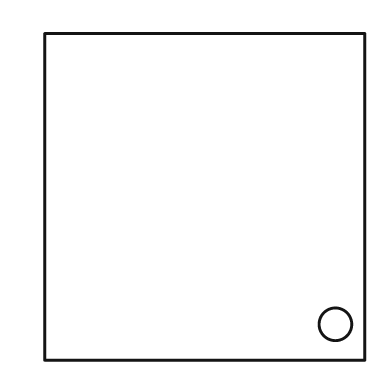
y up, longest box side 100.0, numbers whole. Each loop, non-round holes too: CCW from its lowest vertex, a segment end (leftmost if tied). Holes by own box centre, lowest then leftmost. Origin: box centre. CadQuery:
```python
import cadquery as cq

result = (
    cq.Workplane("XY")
    .moveTo(-49.0, -50.0)
    .lineTo(49.0, -50.0)
    .lineTo(49.0, 50.0)
    .lineTo(-49.0, 50.0)
    .close()
    .moveTo(40.0, -39.0)
    .circle(5.0)
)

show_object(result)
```